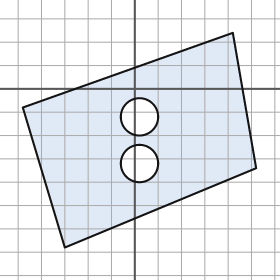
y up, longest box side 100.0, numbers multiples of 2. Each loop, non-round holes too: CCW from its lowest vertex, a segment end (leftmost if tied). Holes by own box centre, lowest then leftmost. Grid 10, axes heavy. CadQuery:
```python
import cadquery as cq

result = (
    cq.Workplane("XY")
    .moveTo(-30.0, -68.0)
    .lineTo(52.0, -34.0)
    .lineTo(42.0, 24.0)
    .lineTo(-48.0, -8.0)
    .close()
    .moveTo(2.0, -32.0)
    .circle(8.0)
    .moveTo(2.0, -12.0)
    .circle(8.0)
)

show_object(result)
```